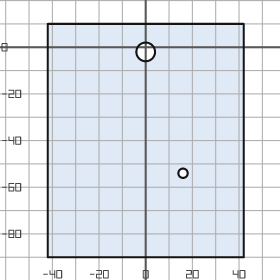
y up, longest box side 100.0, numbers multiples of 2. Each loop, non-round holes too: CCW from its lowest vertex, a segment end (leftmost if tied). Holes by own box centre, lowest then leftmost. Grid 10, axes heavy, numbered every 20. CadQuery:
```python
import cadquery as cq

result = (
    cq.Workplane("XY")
    .moveTo(-42.0, -90.0)
    .lineTo(42.0, -90.0)
    .lineTo(42.0, 10.0)
    .lineTo(-42.0, 10.0)
    .close()
    .moveTo(16.0, -54.0)
    .circle(2.0)
    .moveTo(0.0, -2.0)
    .circle(4.0)
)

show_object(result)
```